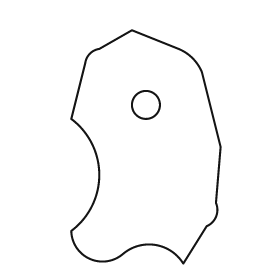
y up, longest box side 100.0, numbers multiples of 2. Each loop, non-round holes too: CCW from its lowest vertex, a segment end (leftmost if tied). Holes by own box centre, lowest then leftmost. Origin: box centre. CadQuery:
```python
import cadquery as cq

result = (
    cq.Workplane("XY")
    .moveTo(16.0, -50.0)
    .lineTo(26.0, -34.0)
    .threePointArc((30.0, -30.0), (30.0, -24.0))
    .lineTo(32.0, 0.0)
    .lineTo(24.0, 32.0)
    .threePointArc((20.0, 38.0), (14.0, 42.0))
    .lineTo(-6.0, 50.0)
    .lineTo(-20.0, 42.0)
    .threePointArc((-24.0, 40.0), (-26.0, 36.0))
    .lineTo(-32.0, 12.0)
    .threePointArc((-20.0, -12.0), (-32.0, -36.0))
    .threePointArc((-24.0, -48.0), (-10.0, -46.0))
    .threePointArc((4.0, -42.0), (16.0, -50.0))
    .close()
    .moveTo(0.0, 18.0)
    .circle(6.0)
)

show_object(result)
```